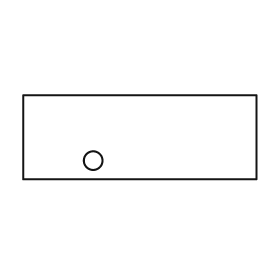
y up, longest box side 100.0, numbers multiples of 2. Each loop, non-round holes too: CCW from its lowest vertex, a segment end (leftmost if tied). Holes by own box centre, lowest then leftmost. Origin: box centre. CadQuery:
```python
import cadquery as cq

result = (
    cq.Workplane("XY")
    .moveTo(-50.0, -18.0)
    .lineTo(50.0, -18.0)
    .lineTo(50.0, 18.0)
    .lineTo(-50.0, 18.0)
    .close()
    .moveTo(-20.0, -10.0)
    .circle(4.0)
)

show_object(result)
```